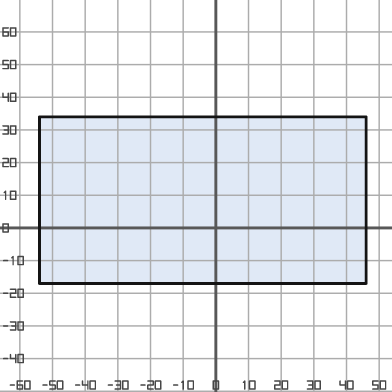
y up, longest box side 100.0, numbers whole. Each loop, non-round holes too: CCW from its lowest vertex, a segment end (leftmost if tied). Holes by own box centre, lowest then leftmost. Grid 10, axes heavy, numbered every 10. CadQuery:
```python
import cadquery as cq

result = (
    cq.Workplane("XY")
    .moveTo(-54.0, -17.0)
    .lineTo(46.0, -17.0)
    .lineTo(46.0, 34.0)
    .lineTo(-54.0, 34.0)
    .close()
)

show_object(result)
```